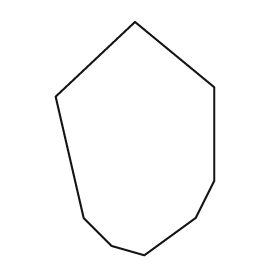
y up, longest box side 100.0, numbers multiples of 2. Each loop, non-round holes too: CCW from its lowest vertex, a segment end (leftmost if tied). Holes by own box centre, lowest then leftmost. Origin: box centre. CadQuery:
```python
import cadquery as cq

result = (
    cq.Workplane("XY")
    .moveTo(4.0, -50.0)
    .lineTo(26.0, -34.0)
    .lineTo(34.0, -18.0)
    .lineTo(34.0, 22.0)
    .lineTo(0.0, 50.0)
    .lineTo(-34.0, 18.0)
    .lineTo(-22.0, -34.0)
    .lineTo(-10.0, -46.0)
    .close()
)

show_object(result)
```